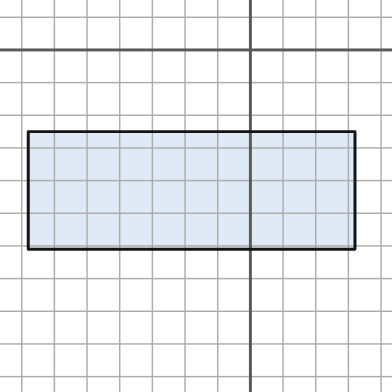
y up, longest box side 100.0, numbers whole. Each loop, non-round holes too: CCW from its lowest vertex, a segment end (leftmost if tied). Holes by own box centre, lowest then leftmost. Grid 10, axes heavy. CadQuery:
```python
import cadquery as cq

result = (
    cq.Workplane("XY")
    .moveTo(-68.0, -61.0)
    .lineTo(32.0, -61.0)
    .lineTo(32.0, -25.0)
    .lineTo(-68.0, -25.0)
    .close()
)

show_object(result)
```